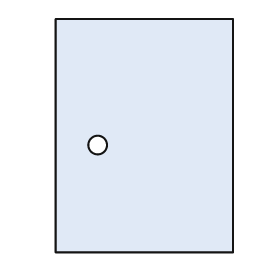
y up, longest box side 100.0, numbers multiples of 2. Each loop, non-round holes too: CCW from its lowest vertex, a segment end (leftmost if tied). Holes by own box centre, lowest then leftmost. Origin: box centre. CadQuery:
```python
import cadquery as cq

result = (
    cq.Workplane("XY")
    .moveTo(-38.0, -50.0)
    .lineTo(38.0, -50.0)
    .lineTo(38.0, 50.0)
    .lineTo(-38.0, 50.0)
    .close()
    .moveTo(-20.0, -4.0)
    .circle(4.0)
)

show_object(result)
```